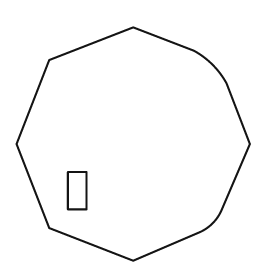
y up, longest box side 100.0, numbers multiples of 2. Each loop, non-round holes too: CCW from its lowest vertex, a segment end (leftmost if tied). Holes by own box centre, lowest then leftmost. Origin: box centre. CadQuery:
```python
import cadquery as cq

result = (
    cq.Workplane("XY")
    .moveTo(0.0, -50.0)
    .lineTo(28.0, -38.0)
    .threePointArc((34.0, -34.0), (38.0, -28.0))
    .lineTo(50.0, 0.0)
    .lineTo(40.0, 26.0)
    .threePointArc((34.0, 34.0), (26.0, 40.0))
    .lineTo(0.0, 50.0)
    .lineTo(-36.0, 36.0)
    .lineTo(-50.0, 0.0)
    .lineTo(-36.0, -36.0)
    .close()
    .moveTo(-28.0, -28.0)
    .lineTo(-20.0, -28.0)
    .lineTo(-20.0, -12.0)
    .lineTo(-28.0, -12.0)
    .close()
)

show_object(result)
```